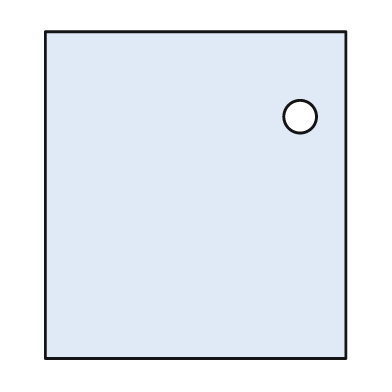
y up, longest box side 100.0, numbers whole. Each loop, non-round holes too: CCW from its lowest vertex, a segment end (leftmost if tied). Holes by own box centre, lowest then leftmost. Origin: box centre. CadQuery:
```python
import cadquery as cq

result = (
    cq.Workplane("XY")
    .moveTo(-46.0, -50.0)
    .lineTo(46.0, -50.0)
    .lineTo(46.0, 50.0)
    .lineTo(-46.0, 50.0)
    .close()
    .moveTo(32.0, 24.0)
    .circle(5.0)
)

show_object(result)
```